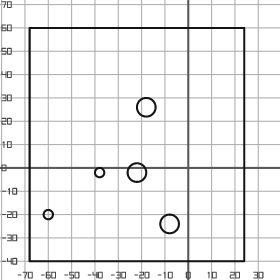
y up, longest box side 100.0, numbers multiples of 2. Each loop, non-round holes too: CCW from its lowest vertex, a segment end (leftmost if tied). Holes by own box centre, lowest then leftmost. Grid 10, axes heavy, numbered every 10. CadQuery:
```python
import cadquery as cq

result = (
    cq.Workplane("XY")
    .moveTo(-68.0, -40.0)
    .lineTo(24.0, -40.0)
    .lineTo(24.0, 60.0)
    .lineTo(-68.0, 60.0)
    .close()
    .moveTo(-8.0, -24.0)
    .circle(4.0)
    .moveTo(-60.0, -20.0)
    .circle(2.0)
    .moveTo(-38.0, -2.0)
    .circle(2.0)
    .moveTo(-22.0, -2.0)
    .circle(4.0)
    .moveTo(-18.0, 26.0)
    .circle(4.0)
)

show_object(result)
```